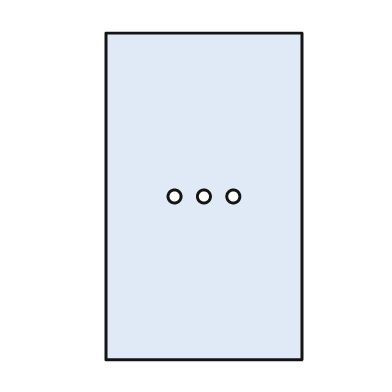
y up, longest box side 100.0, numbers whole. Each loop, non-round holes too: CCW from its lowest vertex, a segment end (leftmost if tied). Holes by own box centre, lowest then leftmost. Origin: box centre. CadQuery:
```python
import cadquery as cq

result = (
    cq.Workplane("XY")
    .moveTo(-30.0, -50.0)
    .lineTo(30.0, -50.0)
    .lineTo(30.0, 50.0)
    .lineTo(-30.0, 50.0)
    .close()
    .moveTo(-9.0, 0.0)
    .circle(2.0)
    .moveTo(0.0, 0.0)
    .circle(2.0)
    .moveTo(9.0, 0.0)
    .circle(2.0)
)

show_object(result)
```